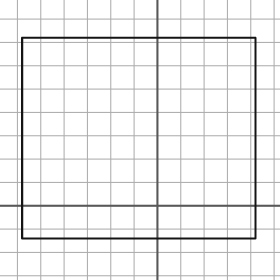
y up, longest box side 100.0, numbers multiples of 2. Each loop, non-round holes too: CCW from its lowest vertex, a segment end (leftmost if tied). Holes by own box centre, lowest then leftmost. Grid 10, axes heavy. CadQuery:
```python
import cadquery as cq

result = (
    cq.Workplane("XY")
    .moveTo(-58.0, -14.0)
    .lineTo(42.0, -14.0)
    .lineTo(42.0, 72.0)
    .lineTo(-58.0, 72.0)
    .close()
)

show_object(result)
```